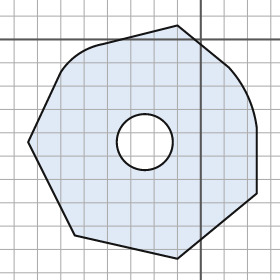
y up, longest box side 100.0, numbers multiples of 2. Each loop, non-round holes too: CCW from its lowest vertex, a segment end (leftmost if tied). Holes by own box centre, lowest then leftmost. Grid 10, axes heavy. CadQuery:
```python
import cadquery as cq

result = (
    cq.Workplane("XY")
    .moveTo(-10.0, -94.0)
    .lineTo(24.0, -66.0)
    .lineTo(24.0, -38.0)
    .threePointArc((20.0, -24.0), (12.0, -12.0))
    .lineTo(-10.0, 6.0)
    .lineTo(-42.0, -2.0)
    .threePointArc((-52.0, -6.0), (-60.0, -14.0))
    .lineTo(-74.0, -44.0)
    .lineTo(-54.0, -84.0)
    .close()
    .moveTo(-24.0, -44.0)
    .circle(12.0)
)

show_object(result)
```